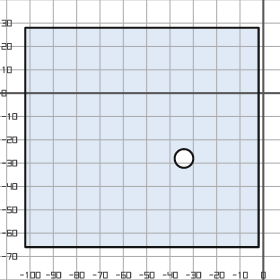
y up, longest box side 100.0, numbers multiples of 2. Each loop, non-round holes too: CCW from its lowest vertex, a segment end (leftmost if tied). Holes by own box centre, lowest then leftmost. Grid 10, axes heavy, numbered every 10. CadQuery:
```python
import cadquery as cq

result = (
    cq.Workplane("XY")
    .moveTo(-102.0, -66.0)
    .lineTo(-2.0, -66.0)
    .lineTo(-2.0, 28.0)
    .lineTo(-102.0, 28.0)
    .close()
    .moveTo(-34.0, -28.0)
    .circle(4.0)
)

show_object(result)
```